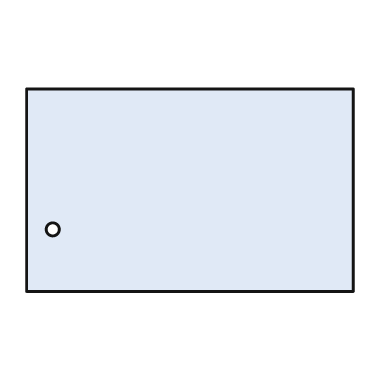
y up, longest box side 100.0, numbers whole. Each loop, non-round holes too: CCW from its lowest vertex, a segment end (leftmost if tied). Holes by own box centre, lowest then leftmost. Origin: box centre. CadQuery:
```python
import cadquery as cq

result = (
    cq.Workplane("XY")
    .moveTo(-50.0, -31.0)
    .lineTo(50.0, -31.0)
    .lineTo(50.0, 31.0)
    .lineTo(-50.0, 31.0)
    .close()
    .moveTo(-42.0, -12.0)
    .circle(2.0)
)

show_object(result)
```